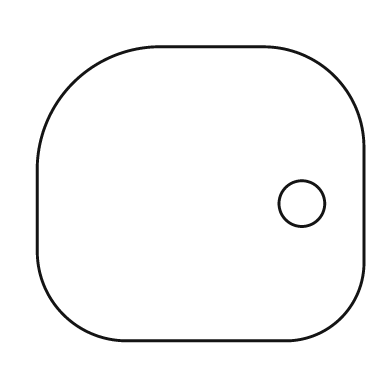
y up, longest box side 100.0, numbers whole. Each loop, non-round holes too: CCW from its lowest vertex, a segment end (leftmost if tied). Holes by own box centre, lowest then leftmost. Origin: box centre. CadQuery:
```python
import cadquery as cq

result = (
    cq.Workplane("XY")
    .moveTo(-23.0, -45.0)
    .lineTo(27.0, -45.0)
    .threePointArc((43.0, -38.0), (50.0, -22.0))
    .lineTo(50.0, 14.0)
    .threePointArc((41.0, 36.0), (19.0, 45.0))
    .lineTo(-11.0, 45.0)
    .threePointArc((-39.0, 34.0), (-50.0, 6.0))
    .lineTo(-50.0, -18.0)
    .threePointArc((-42.0, -37.0), (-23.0, -45.0))
    .close()
    .moveTo(31.0, -3.0)
    .circle(7.0)
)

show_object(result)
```